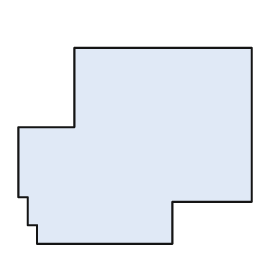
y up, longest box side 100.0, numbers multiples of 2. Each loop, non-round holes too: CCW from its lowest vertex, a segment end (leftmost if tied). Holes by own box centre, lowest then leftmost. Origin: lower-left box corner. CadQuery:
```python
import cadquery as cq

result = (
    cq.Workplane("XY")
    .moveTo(8.0, 0.0)
    .lineTo(66.0, 0.0)
    .lineTo(66.0, 18.0)
    .lineTo(100.0, 18.0)
    .lineTo(100.0, 84.0)
    .lineTo(24.0, 84.0)
    .lineTo(24.0, 50.0)
    .lineTo(0.0, 50.0)
    .lineTo(0.0, 20.0)
    .lineTo(4.0, 20.0)
    .lineTo(4.0, 8.0)
    .lineTo(8.0, 8.0)
    .close()
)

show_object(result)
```